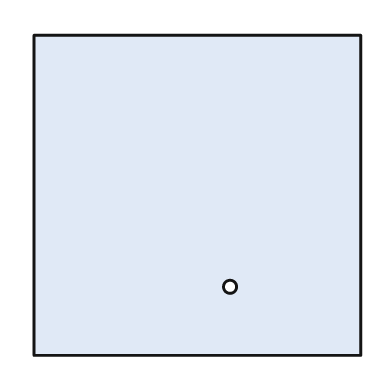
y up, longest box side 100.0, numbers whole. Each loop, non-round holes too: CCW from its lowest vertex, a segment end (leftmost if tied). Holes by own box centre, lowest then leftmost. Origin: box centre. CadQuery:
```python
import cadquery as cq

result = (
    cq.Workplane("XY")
    .moveTo(-50.0, -49.0)
    .lineTo(50.0, -49.0)
    .lineTo(50.0, 49.0)
    .lineTo(-50.0, 49.0)
    .close()
    .moveTo(10.0, -28.0)
    .circle(2.0)
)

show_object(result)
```